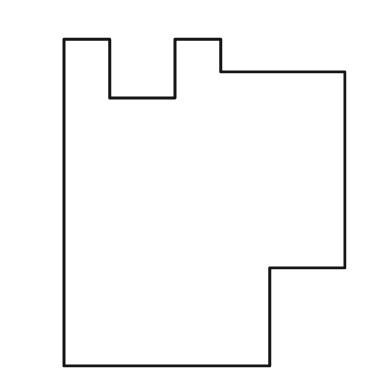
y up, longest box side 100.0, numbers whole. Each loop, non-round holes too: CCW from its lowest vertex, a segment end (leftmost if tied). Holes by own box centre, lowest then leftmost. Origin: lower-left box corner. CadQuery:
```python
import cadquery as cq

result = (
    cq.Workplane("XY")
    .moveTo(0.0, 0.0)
    .lineTo(63.0, 0.0)
    .lineTo(63.0, 30.0)
    .lineTo(86.0, 30.0)
    .lineTo(86.0, 90.0)
    .lineTo(48.0, 90.0)
    .lineTo(48.0, 100.0)
    .lineTo(34.0, 100.0)
    .lineTo(34.0, 82.0)
    .lineTo(14.0, 82.0)
    .lineTo(14.0, 100.0)
    .lineTo(0.0, 100.0)
    .close()
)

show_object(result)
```